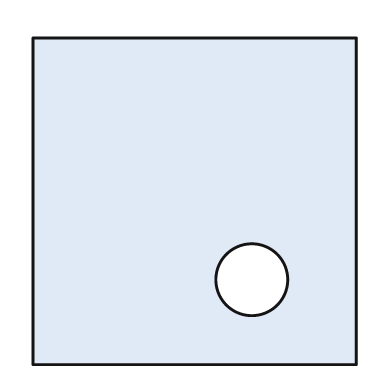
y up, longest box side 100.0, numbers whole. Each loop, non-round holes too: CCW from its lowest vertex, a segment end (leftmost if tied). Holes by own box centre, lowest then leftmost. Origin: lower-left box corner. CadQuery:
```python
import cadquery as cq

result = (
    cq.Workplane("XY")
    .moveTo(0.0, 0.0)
    .lineTo(99.0, 0.0)
    .lineTo(99.0, 100.0)
    .lineTo(0.0, 100.0)
    .close()
    .moveTo(67.0, 26.0)
    .circle(11.0)
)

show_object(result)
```